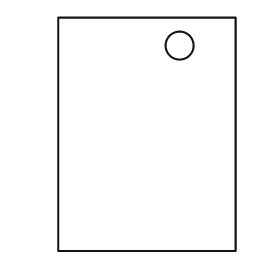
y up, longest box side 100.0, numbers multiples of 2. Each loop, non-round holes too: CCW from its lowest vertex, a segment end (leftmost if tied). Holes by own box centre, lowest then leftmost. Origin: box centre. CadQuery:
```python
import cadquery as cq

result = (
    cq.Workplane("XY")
    .moveTo(-38.0, -50.0)
    .lineTo(38.0, -50.0)
    .lineTo(38.0, 50.0)
    .lineTo(-38.0, 50.0)
    .close()
    .moveTo(14.0, 38.0)
    .circle(6.0)
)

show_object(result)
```